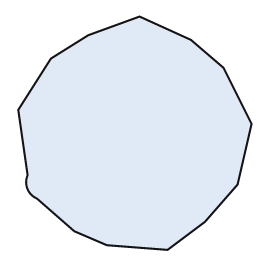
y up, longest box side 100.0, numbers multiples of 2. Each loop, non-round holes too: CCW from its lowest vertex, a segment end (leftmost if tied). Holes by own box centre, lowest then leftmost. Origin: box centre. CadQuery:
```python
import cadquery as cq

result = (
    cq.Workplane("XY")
    .moveTo(14.0, -50.0)
    .lineTo(30.0, -38.0)
    .lineTo(44.0, -22.0)
    .lineTo(50.0, 4.0)
    .lineTo(38.0, 28.0)
    .lineTo(24.0, 40.0)
    .lineTo(2.0, 50.0)
    .lineTo(-20.0, 42.0)
    .lineTo(-36.0, 32.0)
    .lineTo(-50.0, 10.0)
    .lineTo(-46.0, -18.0)
    .threePointArc((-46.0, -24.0), (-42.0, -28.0))
    .lineTo(-26.0, -42.0)
    .lineTo(-12.0, -48.0)
    .close()
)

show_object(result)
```